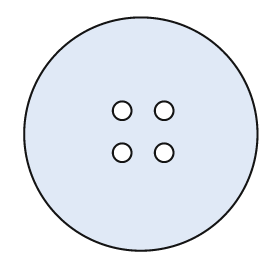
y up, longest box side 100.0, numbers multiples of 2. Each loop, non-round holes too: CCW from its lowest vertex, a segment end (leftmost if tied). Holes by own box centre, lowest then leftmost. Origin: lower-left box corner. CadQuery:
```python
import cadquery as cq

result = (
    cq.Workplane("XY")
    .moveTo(50.0, 50.0)
    .circle(50.0)
    .moveTo(42.0, 42.0)
    .circle(4.0)
    .moveTo(60.0, 42.0)
    .circle(4.0)
    .moveTo(42.0, 60.0)
    .circle(4.0)
    .moveTo(60.0, 60.0)
    .circle(4.0)
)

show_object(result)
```